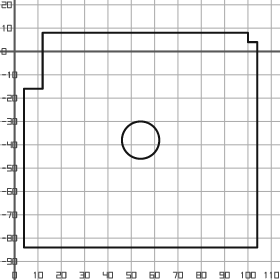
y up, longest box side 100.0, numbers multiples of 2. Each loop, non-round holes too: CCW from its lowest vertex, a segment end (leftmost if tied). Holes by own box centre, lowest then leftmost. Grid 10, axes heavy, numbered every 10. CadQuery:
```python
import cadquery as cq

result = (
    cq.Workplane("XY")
    .moveTo(4.0, -84.0)
    .lineTo(104.0, -84.0)
    .lineTo(104.0, 4.0)
    .lineTo(100.0, 4.0)
    .lineTo(100.0, 8.0)
    .lineTo(12.0, 8.0)
    .lineTo(12.0, -16.0)
    .lineTo(4.0, -16.0)
    .close()
    .moveTo(54.0, -38.0)
    .circle(8.0)
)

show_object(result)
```